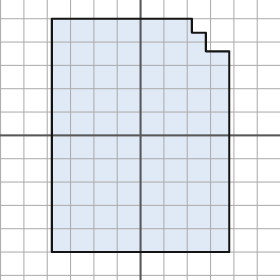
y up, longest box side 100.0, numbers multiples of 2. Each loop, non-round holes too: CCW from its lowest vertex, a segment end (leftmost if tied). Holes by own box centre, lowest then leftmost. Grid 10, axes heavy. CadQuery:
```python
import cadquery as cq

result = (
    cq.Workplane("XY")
    .moveTo(-38.0, -50.0)
    .lineTo(38.0, -50.0)
    .lineTo(38.0, 36.0)
    .lineTo(28.0, 36.0)
    .lineTo(28.0, 44.0)
    .lineTo(22.0, 44.0)
    .lineTo(22.0, 50.0)
    .lineTo(-38.0, 50.0)
    .close()
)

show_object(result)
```